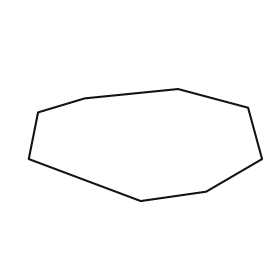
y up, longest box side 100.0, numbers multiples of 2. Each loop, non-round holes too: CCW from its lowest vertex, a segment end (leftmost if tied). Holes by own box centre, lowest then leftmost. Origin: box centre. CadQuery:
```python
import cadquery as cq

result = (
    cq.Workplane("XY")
    .moveTo(-2.0, -24.0)
    .lineTo(26.0, -20.0)
    .lineTo(50.0, -6.0)
    .lineTo(44.0, 16.0)
    .lineTo(14.0, 24.0)
    .lineTo(-26.0, 20.0)
    .lineTo(-46.0, 14.0)
    .lineTo(-50.0, -6.0)
    .close()
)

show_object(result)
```